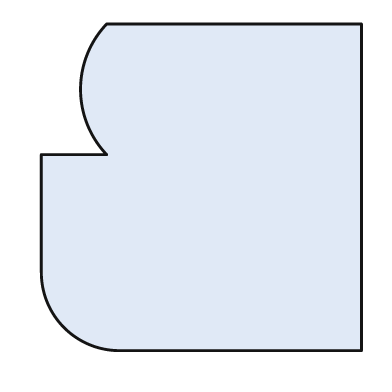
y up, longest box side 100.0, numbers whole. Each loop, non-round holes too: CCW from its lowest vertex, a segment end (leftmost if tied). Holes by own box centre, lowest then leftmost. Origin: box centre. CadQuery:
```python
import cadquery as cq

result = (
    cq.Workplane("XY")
    .moveTo(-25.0, -50.0)
    .lineTo(49.0, -50.0)
    .lineTo(49.0, 50.0)
    .lineTo(-29.0, 50.0)
    .threePointArc((-37.0, 30.0), (-29.0, 10.0))
    .lineTo(-49.0, 10.0)
    .lineTo(-49.0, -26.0)
    .threePointArc((-42.0, -43.0), (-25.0, -50.0))
    .close()
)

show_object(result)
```